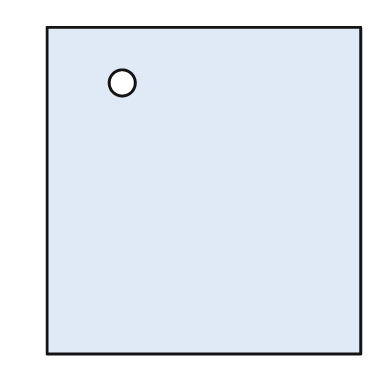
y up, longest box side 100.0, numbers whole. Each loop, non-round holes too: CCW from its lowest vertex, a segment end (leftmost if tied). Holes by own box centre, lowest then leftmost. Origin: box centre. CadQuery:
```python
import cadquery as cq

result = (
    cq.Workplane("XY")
    .moveTo(-48.0, -50.0)
    .lineTo(48.0, -50.0)
    .lineTo(48.0, 50.0)
    .lineTo(-48.0, 50.0)
    .close()
    .moveTo(-25.0, 33.0)
    .circle(4.0)
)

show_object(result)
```